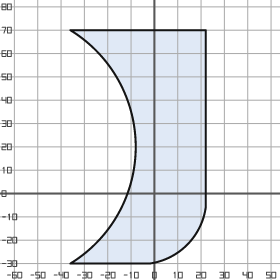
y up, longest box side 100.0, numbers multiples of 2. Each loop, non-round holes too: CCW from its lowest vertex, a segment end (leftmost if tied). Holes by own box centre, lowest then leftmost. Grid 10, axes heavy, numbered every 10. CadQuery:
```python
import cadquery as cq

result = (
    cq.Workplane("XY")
    .moveTo(-36.0, -30.0)
    .lineTo(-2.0, -30.0)
    .threePointArc((14.0, -22.0), (22.0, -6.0))
    .lineTo(22.0, 70.0)
    .lineTo(-36.0, 70.0)
    .threePointArc((-8.0, 20.0), (-36.0, -30.0))
    .close()
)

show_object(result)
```